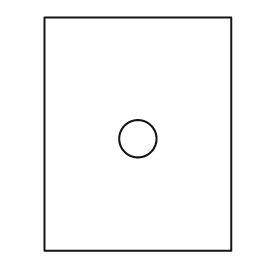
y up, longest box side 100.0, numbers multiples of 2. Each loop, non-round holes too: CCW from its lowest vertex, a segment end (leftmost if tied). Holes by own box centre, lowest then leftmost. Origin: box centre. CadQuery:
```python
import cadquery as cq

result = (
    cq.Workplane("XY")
    .moveTo(-40.0, -50.0)
    .lineTo(40.0, -50.0)
    .lineTo(40.0, 50.0)
    .lineTo(-40.0, 50.0)
    .close()
    .moveTo(0.0, -2.0)
    .circle(8.0)
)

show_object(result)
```